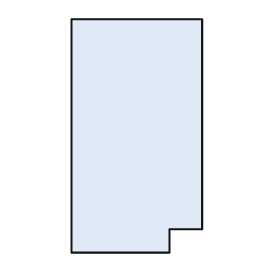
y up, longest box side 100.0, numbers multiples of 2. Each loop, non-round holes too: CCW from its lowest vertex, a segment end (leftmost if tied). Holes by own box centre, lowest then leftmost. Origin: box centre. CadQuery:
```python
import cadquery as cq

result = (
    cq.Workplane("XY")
    .moveTo(-28.0, -50.0)
    .lineTo(14.0, -50.0)
    .lineTo(14.0, -40.0)
    .lineTo(28.0, -40.0)
    .lineTo(28.0, 50.0)
    .lineTo(-28.0, 50.0)
    .close()
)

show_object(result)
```